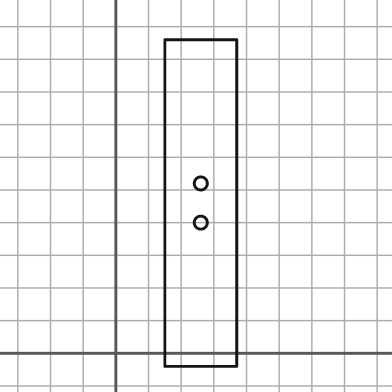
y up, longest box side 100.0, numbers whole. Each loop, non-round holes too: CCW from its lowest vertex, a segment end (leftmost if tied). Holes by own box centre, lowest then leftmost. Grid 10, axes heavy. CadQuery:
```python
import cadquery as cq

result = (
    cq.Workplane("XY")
    .moveTo(15.0, -4.0)
    .lineTo(37.0, -4.0)
    .lineTo(37.0, 96.0)
    .lineTo(15.0, 96.0)
    .close()
    .moveTo(26.0, 40.0)
    .circle(2.0)
    .moveTo(26.0, 52.0)
    .circle(2.0)
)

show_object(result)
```